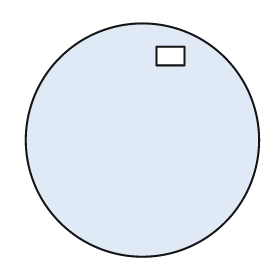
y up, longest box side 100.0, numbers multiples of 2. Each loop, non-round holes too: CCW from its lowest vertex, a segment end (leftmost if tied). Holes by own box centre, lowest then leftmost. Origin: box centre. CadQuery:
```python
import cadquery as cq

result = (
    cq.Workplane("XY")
    .moveTo(0.0, 0.0)
    .circle(50.0)
    .moveTo(6.0, 32.0)
    .lineTo(18.0, 32.0)
    .lineTo(18.0, 40.0)
    .lineTo(6.0, 40.0)
    .close()
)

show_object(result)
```